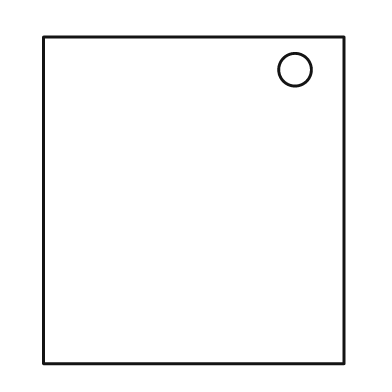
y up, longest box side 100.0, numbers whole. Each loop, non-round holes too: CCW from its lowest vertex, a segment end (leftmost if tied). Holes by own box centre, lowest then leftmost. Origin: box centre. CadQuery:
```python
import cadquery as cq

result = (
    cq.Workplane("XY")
    .moveTo(-46.0, -50.0)
    .lineTo(46.0, -50.0)
    .lineTo(46.0, 50.0)
    .lineTo(-46.0, 50.0)
    .close()
    .moveTo(31.0, 40.0)
    .circle(5.0)
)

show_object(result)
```